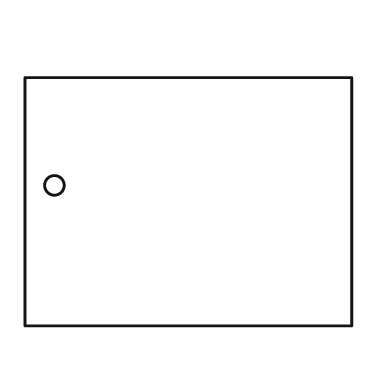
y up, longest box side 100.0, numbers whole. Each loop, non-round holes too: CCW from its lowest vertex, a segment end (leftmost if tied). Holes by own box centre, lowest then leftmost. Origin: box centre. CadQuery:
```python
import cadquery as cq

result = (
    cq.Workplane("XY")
    .moveTo(-50.0, -38.0)
    .lineTo(50.0, -38.0)
    .lineTo(50.0, 38.0)
    .lineTo(-50.0, 38.0)
    .close()
    .moveTo(-41.0, 5.0)
    .circle(3.0)
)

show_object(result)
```